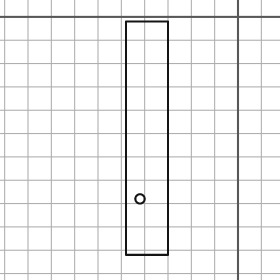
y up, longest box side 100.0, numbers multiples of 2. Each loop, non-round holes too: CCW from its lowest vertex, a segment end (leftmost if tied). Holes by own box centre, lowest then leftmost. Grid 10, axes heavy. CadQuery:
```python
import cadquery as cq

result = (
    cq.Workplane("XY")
    .moveTo(-48.0, -102.0)
    .lineTo(-30.0, -102.0)
    .lineTo(-30.0, -2.0)
    .lineTo(-48.0, -2.0)
    .close()
    .moveTo(-42.0, -78.0)
    .circle(2.0)
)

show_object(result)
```